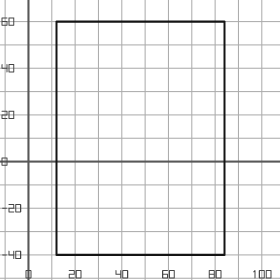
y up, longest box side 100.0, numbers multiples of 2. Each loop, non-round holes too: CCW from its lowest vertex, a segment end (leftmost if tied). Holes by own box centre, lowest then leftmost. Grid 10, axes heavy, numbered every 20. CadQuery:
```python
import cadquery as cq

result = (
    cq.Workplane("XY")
    .moveTo(12.0, -40.0)
    .lineTo(84.0, -40.0)
    .lineTo(84.0, 60.0)
    .lineTo(12.0, 60.0)
    .close()
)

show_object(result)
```